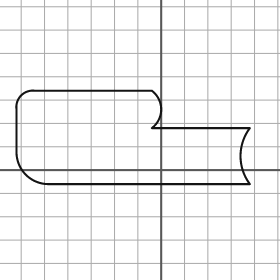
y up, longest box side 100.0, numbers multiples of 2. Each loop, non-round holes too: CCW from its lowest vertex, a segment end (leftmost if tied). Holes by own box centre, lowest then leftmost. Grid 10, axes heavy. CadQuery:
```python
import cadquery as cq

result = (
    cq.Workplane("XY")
    .moveTo(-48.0, -6.0)
    .lineTo(38.0, -6.0)
    .threePointArc((34.0, 6.0), (38.0, 18.0))
    .lineTo(-4.0, 18.0)
    .threePointArc((0.0, 26.0), (-4.0, 34.0))
    .lineTo(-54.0, 34.0)
    .threePointArc((-60.0, 32.0), (-62.0, 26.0))
    .lineTo(-62.0, 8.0)
    .threePointArc((-58.0, -2.0), (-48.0, -6.0))
    .close()
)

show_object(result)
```